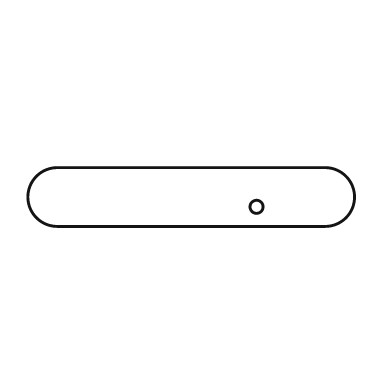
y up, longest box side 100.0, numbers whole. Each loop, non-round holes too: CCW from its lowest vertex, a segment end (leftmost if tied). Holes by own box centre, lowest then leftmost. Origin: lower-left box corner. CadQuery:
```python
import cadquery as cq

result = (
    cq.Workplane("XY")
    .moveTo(9.0, 0.0)
    .lineTo(91.0, 0.0)
    .threePointArc((100.0, 9.0), (91.0, 18.0))
    .lineTo(9.0, 18.0)
    .threePointArc((0.0, 9.0), (9.0, 0.0))
    .close()
    .moveTo(70.0, 6.0)
    .circle(2.0)
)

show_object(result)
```